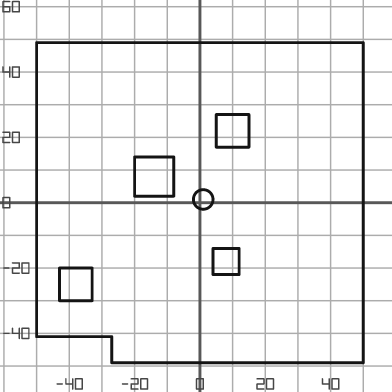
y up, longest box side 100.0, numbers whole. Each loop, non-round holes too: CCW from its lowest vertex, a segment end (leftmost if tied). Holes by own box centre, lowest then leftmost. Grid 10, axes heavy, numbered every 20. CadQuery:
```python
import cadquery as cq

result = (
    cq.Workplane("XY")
    .moveTo(-27.0, -49.0)
    .lineTo(50.0, -49.0)
    .lineTo(50.0, 49.0)
    .lineTo(-50.0, 49.0)
    .lineTo(-50.0, -41.0)
    .lineTo(-27.0, -41.0)
    .close()
    .moveTo(-43.0, -30.0)
    .lineTo(-33.0, -30.0)
    .lineTo(-33.0, -20.0)
    .lineTo(-43.0, -20.0)
    .close()
    .moveTo(4.0, -22.0)
    .lineTo(12.0, -22.0)
    .lineTo(12.0, -14.0)
    .lineTo(4.0, -14.0)
    .close()
    .moveTo(1.0, 1.0)
    .circle(3.0)
    .moveTo(-20.0, 2.0)
    .lineTo(-8.0, 2.0)
    .lineTo(-8.0, 14.0)
    .lineTo(-20.0, 14.0)
    .close()
    .moveTo(5.0, 17.0)
    .lineTo(15.0, 17.0)
    .lineTo(15.0, 27.0)
    .lineTo(5.0, 27.0)
    .close()
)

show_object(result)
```